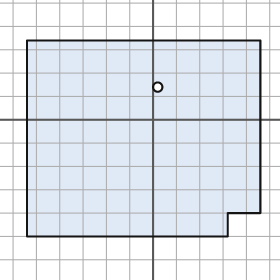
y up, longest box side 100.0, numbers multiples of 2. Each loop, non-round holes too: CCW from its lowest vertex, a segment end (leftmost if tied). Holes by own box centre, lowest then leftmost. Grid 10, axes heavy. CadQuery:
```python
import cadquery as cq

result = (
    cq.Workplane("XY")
    .moveTo(-54.0, -50.0)
    .lineTo(32.0, -50.0)
    .lineTo(32.0, -40.0)
    .lineTo(46.0, -40.0)
    .lineTo(46.0, 34.0)
    .lineTo(-54.0, 34.0)
    .close()
    .moveTo(2.0, 14.0)
    .circle(2.0)
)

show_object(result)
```